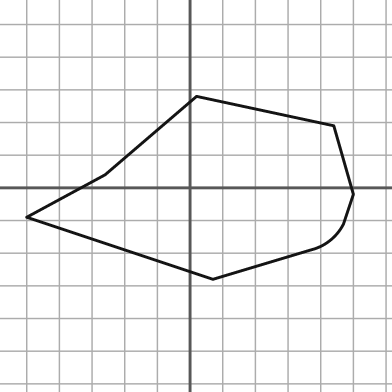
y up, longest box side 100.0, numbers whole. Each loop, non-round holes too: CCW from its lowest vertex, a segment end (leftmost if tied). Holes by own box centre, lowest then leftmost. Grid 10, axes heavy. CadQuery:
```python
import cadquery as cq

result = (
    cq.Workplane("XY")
    .moveTo(7.0, -28.0)
    .lineTo(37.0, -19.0)
    .threePointArc((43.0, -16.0), (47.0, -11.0))
    .lineTo(50.0, -2.0)
    .lineTo(44.0, 19.0)
    .lineTo(2.0, 28.0)
    .lineTo(-26.0, 4.0)
    .lineTo(-50.0, -9.0)
    .close()
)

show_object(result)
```